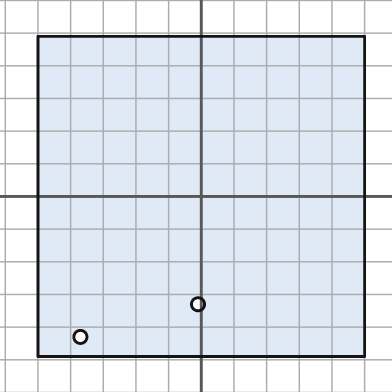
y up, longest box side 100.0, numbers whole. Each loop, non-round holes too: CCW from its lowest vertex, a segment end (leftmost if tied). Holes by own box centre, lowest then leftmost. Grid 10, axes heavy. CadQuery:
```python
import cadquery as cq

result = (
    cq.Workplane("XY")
    .moveTo(-50.0, -49.0)
    .lineTo(50.0, -49.0)
    .lineTo(50.0, 49.0)
    .lineTo(-50.0, 49.0)
    .close()
    .moveTo(-37.0, -43.0)
    .circle(2.0)
    .moveTo(-1.0, -33.0)
    .circle(2.0)
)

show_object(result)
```